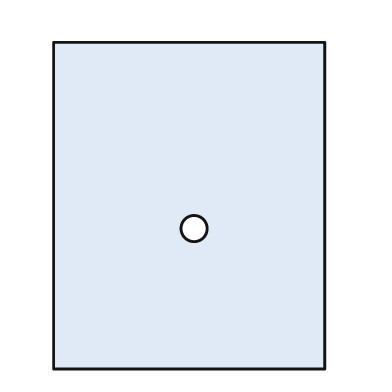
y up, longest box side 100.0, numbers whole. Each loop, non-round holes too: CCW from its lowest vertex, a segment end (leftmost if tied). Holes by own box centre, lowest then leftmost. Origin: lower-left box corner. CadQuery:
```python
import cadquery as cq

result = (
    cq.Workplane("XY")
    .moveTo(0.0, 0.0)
    .lineTo(83.0, 0.0)
    .lineTo(83.0, 100.0)
    .lineTo(0.0, 100.0)
    .close()
    .moveTo(43.0, 43.0)
    .circle(4.0)
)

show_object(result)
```